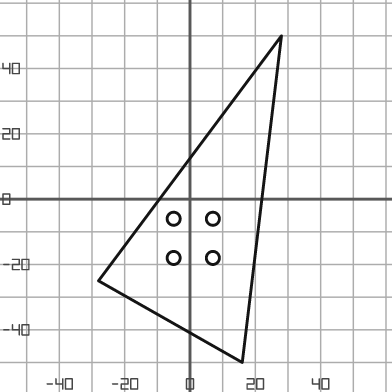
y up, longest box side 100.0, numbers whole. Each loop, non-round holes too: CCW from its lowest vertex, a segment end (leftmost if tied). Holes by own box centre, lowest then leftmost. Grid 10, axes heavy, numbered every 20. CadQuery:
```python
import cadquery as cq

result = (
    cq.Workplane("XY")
    .moveTo(16.0, -50.0)
    .lineTo(28.0, 50.0)
    .lineTo(-28.0, -25.0)
    .close()
    .moveTo(-5.0, -18.0)
    .circle(2.0)
    .moveTo(7.0, -18.0)
    .circle(2.0)
    .moveTo(-5.0, -6.0)
    .circle(2.0)
    .moveTo(7.0, -6.0)
    .circle(2.0)
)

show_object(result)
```